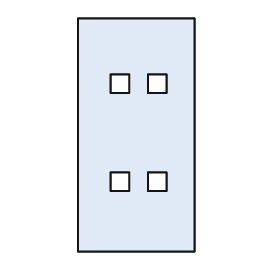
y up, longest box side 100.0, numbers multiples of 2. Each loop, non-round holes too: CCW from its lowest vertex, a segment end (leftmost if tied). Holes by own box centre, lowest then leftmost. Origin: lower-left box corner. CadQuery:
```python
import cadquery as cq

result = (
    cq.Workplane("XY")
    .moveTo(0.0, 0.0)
    .lineTo(50.0, 0.0)
    .lineTo(50.0, 100.0)
    .lineTo(0.0, 100.0)
    .close()
    .moveTo(14.0, 26.0)
    .lineTo(22.0, 26.0)
    .lineTo(22.0, 34.0)
    .lineTo(14.0, 34.0)
    .close()
    .moveTo(30.0, 26.0)
    .lineTo(38.0, 26.0)
    .lineTo(38.0, 34.0)
    .lineTo(30.0, 34.0)
    .close()
    .moveTo(14.0, 68.0)
    .lineTo(22.0, 68.0)
    .lineTo(22.0, 76.0)
    .lineTo(14.0, 76.0)
    .close()
    .moveTo(30.0, 68.0)
    .lineTo(38.0, 68.0)
    .lineTo(38.0, 76.0)
    .lineTo(30.0, 76.0)
    .close()
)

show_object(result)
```